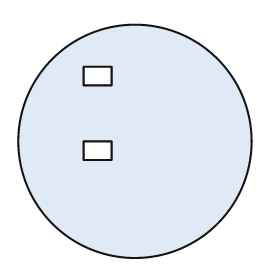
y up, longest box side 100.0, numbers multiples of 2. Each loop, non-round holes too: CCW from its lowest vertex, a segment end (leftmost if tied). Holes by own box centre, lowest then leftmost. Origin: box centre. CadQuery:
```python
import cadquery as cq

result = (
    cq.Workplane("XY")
    .moveTo(0.0, 0.0)
    .circle(50.0)
    .moveTo(-22.0, -8.0)
    .lineTo(-10.0, -8.0)
    .lineTo(-10.0, 0.0)
    .lineTo(-22.0, 0.0)
    .close()
    .moveTo(-22.0, 24.0)
    .lineTo(-10.0, 24.0)
    .lineTo(-10.0, 32.0)
    .lineTo(-22.0, 32.0)
    .close()
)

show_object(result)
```